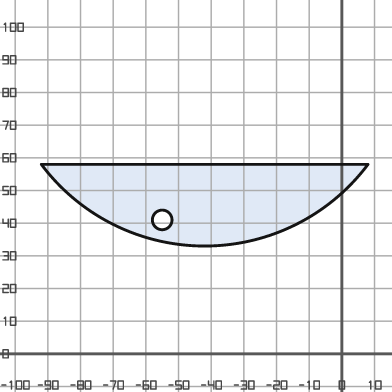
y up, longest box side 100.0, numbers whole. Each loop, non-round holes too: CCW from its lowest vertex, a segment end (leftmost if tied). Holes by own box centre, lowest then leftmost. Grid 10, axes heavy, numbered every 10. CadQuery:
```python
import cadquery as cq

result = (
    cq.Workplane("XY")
    .moveTo(-92.0, 58.0)
    .threePointArc((-42.0, 33.0), (8.0, 58.0))
    .close()
    .moveTo(-55.0, 41.0)
    .circle(3.0)
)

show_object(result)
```